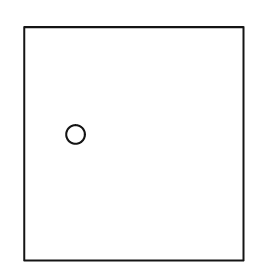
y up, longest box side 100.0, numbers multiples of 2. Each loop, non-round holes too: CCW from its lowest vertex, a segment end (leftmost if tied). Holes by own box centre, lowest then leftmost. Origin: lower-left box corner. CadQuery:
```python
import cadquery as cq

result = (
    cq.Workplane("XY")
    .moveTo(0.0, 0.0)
    .lineTo(94.0, 0.0)
    .lineTo(94.0, 100.0)
    .lineTo(0.0, 100.0)
    .close()
    .moveTo(22.0, 54.0)
    .circle(4.0)
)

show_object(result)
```